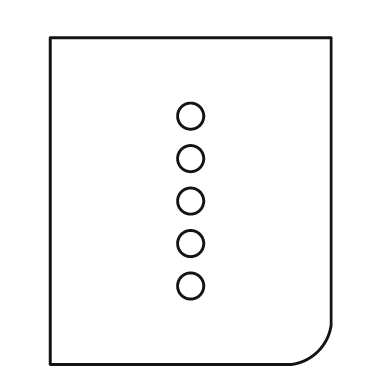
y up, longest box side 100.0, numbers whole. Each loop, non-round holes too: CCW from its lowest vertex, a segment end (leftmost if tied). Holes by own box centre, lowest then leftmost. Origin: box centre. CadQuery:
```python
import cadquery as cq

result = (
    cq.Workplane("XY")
    .moveTo(-43.0, -50.0)
    .lineTo(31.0, -50.0)
    .threePointArc((39.0, -46.0), (43.0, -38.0))
    .lineTo(43.0, 50.0)
    .lineTo(-43.0, 50.0)
    .close()
    .moveTo(0.0, -26.0)
    .circle(4.0)
    .moveTo(0.0, -13.0)
    .circle(4.0)
    .moveTo(0.0, 0.0)
    .circle(4.0)
    .moveTo(0.0, 13.0)
    .circle(4.0)
    .moveTo(0.0, 26.0)
    .circle(4.0)
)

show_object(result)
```